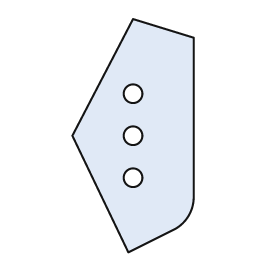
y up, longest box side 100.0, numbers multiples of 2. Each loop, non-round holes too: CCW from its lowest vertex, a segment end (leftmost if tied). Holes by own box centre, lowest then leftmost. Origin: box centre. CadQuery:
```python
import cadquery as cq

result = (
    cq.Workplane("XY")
    .moveTo(-2.0, -50.0)
    .lineTo(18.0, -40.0)
    .threePointArc((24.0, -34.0), (26.0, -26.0))
    .lineTo(26.0, 42.0)
    .lineTo(0.0, 50.0)
    .lineTo(-26.0, 0.0)
    .close()
    .moveTo(0.0, -18.0)
    .circle(4.0)
    .moveTo(0.0, 0.0)
    .circle(4.0)
    .moveTo(0.0, 18.0)
    .circle(4.0)
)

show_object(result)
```